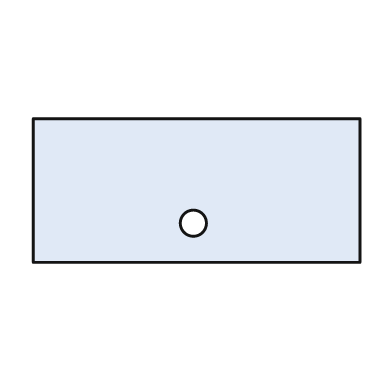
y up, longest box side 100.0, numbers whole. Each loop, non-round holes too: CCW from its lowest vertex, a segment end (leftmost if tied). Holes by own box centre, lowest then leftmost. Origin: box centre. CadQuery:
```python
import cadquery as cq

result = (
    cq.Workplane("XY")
    .moveTo(-50.0, -22.0)
    .lineTo(50.0, -22.0)
    .lineTo(50.0, 22.0)
    .lineTo(-50.0, 22.0)
    .close()
    .moveTo(-1.0, -10.0)
    .circle(4.0)
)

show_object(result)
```